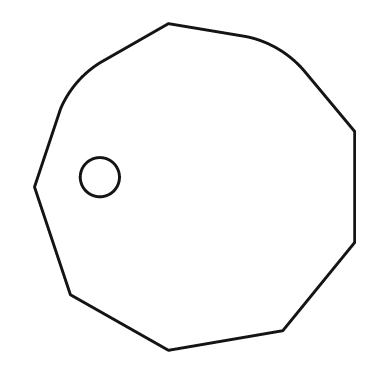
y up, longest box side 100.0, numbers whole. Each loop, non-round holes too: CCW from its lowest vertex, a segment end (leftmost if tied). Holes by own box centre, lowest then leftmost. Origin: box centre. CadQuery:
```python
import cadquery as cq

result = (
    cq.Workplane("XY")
    .moveTo(-8.0, -50.0)
    .lineTo(27.0, -44.0)
    .lineTo(49.0, -17.0)
    .lineTo(49.0, 17.0)
    .lineTo(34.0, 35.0)
    .threePointArc((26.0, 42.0), (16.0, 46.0))
    .lineTo(-8.0, 50.0)
    .lineTo(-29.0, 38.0)
    .threePointArc((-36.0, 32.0), (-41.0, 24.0))
    .lineTo(-49.0, 0.0)
    .lineTo(-38.0, -33.0)
    .close()
    .moveTo(-29.0, 3.0)
    .circle(6.0)
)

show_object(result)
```